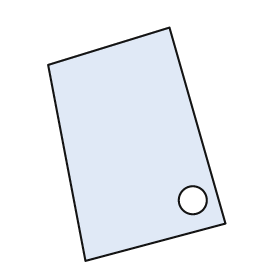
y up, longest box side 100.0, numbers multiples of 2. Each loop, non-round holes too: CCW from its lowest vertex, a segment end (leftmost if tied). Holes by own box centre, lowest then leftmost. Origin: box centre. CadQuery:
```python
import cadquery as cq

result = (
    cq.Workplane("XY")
    .moveTo(-22.0, -50.0)
    .lineTo(38.0, -34.0)
    .lineTo(14.0, 50.0)
    .lineTo(-38.0, 34.0)
    .close()
    .moveTo(24.0, -24.0)
    .circle(6.0)
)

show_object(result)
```